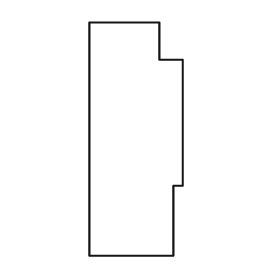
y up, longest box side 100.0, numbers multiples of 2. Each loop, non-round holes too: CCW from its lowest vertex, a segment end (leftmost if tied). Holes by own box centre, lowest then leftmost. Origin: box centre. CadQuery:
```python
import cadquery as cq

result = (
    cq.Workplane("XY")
    .moveTo(-20.0, -50.0)
    .lineTo(16.0, -50.0)
    .lineTo(16.0, -20.0)
    .lineTo(20.0, -20.0)
    .lineTo(20.0, 34.0)
    .lineTo(10.0, 34.0)
    .lineTo(10.0, 50.0)
    .lineTo(-20.0, 50.0)
    .close()
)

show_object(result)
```